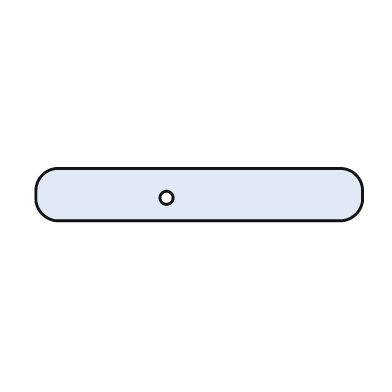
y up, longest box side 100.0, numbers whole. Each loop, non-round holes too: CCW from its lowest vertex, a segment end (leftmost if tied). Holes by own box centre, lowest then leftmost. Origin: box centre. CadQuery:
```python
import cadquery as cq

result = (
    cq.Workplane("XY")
    .moveTo(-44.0, -8.0)
    .lineTo(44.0, -8.0)
    .threePointArc((48.0, -6.0), (50.0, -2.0))
    .lineTo(50.0, 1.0)
    .threePointArc((48.0, 6.0), (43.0, 8.0))
    .lineTo(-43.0, 8.0)
    .threePointArc((-48.0, 6.0), (-50.0, 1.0))
    .lineTo(-50.0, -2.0)
    .threePointArc((-48.0, -6.0), (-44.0, -8.0))
    .close()
    .moveTo(-10.0, -1.0)
    .circle(2.0)
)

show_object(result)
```